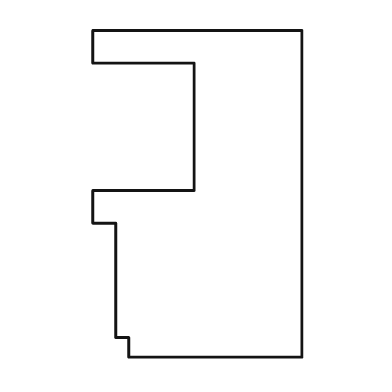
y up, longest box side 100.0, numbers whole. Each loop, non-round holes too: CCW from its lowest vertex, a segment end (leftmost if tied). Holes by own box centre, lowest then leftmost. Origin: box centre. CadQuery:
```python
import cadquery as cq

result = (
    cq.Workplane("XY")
    .moveTo(-21.0, -50.0)
    .lineTo(32.0, -50.0)
    .lineTo(32.0, 50.0)
    .lineTo(-32.0, 50.0)
    .lineTo(-32.0, 40.0)
    .lineTo(-1.0, 40.0)
    .lineTo(-1.0, 1.0)
    .lineTo(-32.0, 1.0)
    .lineTo(-32.0, -9.0)
    .lineTo(-25.0, -9.0)
    .lineTo(-25.0, -44.0)
    .lineTo(-21.0, -44.0)
    .close()
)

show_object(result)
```